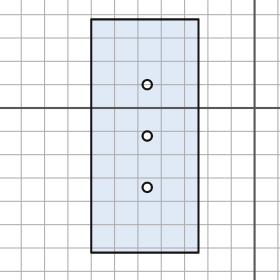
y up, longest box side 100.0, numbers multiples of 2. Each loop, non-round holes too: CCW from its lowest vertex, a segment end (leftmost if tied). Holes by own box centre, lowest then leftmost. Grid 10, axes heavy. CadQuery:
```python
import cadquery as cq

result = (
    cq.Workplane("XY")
    .moveTo(-70.0, -62.0)
    .lineTo(-24.0, -62.0)
    .lineTo(-24.0, 38.0)
    .lineTo(-70.0, 38.0)
    .close()
    .moveTo(-46.0, -34.0)
    .circle(2.0)
    .moveTo(-46.0, -12.0)
    .circle(2.0)
    .moveTo(-46.0, 10.0)
    .circle(2.0)
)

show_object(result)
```